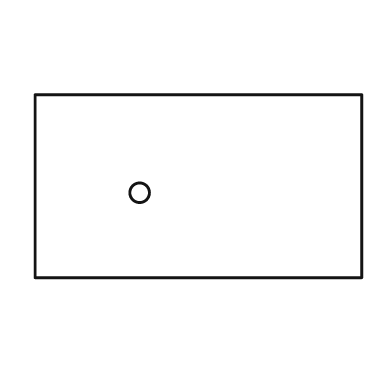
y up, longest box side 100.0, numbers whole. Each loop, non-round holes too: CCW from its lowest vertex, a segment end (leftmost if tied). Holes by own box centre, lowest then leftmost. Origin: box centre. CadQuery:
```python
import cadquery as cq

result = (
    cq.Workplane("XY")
    .moveTo(-50.0, -28.0)
    .lineTo(50.0, -28.0)
    .lineTo(50.0, 28.0)
    .lineTo(-50.0, 28.0)
    .close()
    .moveTo(-18.0, -2.0)
    .circle(3.0)
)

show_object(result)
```